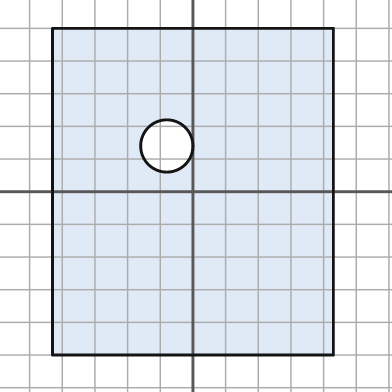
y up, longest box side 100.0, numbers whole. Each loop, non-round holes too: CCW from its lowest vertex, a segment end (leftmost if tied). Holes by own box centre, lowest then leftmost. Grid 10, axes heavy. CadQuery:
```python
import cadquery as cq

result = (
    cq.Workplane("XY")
    .moveTo(-43.0, -50.0)
    .lineTo(43.0, -50.0)
    .lineTo(43.0, 50.0)
    .lineTo(-43.0, 50.0)
    .close()
    .moveTo(-8.0, 14.0)
    .circle(8.0)
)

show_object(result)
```